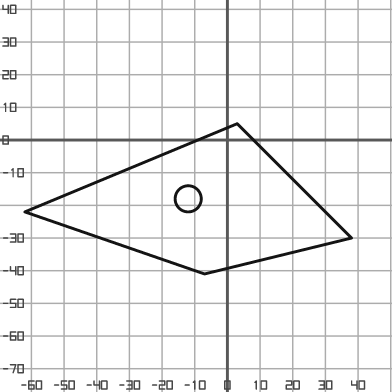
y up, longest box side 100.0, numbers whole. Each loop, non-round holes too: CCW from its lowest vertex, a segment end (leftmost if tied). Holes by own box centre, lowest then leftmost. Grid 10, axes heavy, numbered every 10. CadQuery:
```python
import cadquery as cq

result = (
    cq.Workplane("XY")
    .moveTo(-7.0, -41.0)
    .lineTo(38.0, -30.0)
    .lineTo(3.0, 5.0)
    .lineTo(-62.0, -22.0)
    .close()
    .moveTo(-12.0, -18.0)
    .circle(4.0)
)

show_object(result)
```